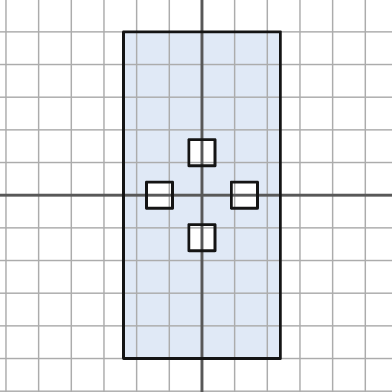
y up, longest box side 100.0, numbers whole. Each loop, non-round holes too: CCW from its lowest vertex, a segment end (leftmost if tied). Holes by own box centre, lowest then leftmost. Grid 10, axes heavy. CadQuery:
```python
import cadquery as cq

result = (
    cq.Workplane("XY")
    .moveTo(-24.0, -50.0)
    .lineTo(24.0, -50.0)
    .lineTo(24.0, 50.0)
    .lineTo(-24.0, 50.0)
    .close()
    .moveTo(-4.0, -17.0)
    .lineTo(4.0, -17.0)
    .lineTo(4.0, -9.0)
    .lineTo(-4.0, -9.0)
    .close()
    .moveTo(-17.0, -4.0)
    .lineTo(-9.0, -4.0)
    .lineTo(-9.0, 4.0)
    .lineTo(-17.0, 4.0)
    .close()
    .moveTo(9.0, -4.0)
    .lineTo(17.0, -4.0)
    .lineTo(17.0, 4.0)
    .lineTo(9.0, 4.0)
    .close()
    .moveTo(-4.0, 9.0)
    .lineTo(4.0, 9.0)
    .lineTo(4.0, 17.0)
    .lineTo(-4.0, 17.0)
    .close()
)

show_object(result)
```